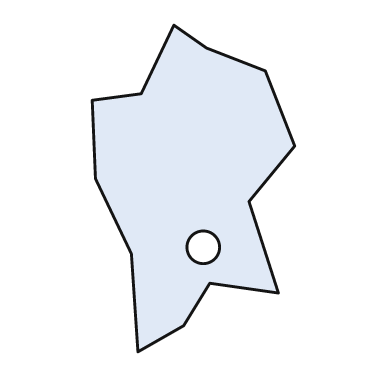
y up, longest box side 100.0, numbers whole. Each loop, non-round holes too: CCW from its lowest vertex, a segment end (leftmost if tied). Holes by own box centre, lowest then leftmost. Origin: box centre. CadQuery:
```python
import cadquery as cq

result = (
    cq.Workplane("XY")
    .moveTo(-17.0, -50.0)
    .lineTo(-3.0, -42.0)
    .lineTo(5.0, -29.0)
    .lineTo(26.0, -32.0)
    .lineTo(17.0, -4.0)
    .lineTo(31.0, 13.0)
    .lineTo(22.0, 36.0)
    .lineTo(4.0, 43.0)
    .lineTo(-6.0, 50.0)
    .lineTo(-16.0, 29.0)
    .lineTo(-31.0, 27.0)
    .lineTo(-30.0, 3.0)
    .lineTo(-19.0, -20.0)
    .close()
    .moveTo(3.0, -18.0)
    .circle(5.0)
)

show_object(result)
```